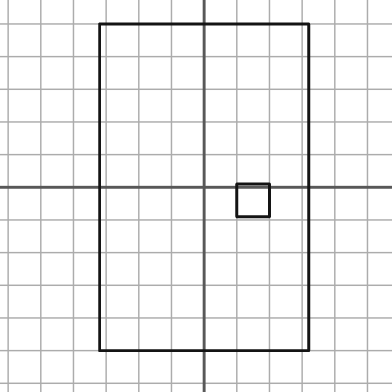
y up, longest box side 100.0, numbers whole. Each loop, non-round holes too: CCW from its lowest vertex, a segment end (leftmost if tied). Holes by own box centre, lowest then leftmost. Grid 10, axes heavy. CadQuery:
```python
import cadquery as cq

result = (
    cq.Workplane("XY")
    .moveTo(-32.0, -50.0)
    .lineTo(32.0, -50.0)
    .lineTo(32.0, 50.0)
    .lineTo(-32.0, 50.0)
    .close()
    .moveTo(10.0, -9.0)
    .lineTo(20.0, -9.0)
    .lineTo(20.0, 1.0)
    .lineTo(10.0, 1.0)
    .close()
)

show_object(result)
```